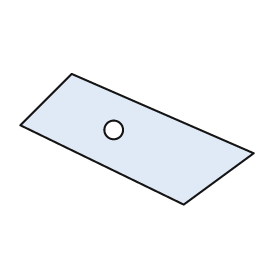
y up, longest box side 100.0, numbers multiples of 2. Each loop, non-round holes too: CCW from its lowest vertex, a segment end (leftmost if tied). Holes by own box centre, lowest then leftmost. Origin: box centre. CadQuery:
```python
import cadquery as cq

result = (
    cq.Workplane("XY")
    .moveTo(20.0, -28.0)
    .lineTo(50.0, -6.0)
    .lineTo(-28.0, 28.0)
    .lineTo(-50.0, 6.0)
    .close()
    .moveTo(-10.0, 4.0)
    .circle(4.0)
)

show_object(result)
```